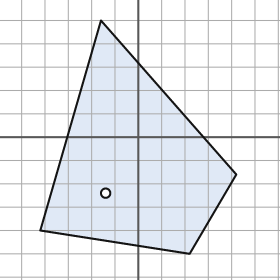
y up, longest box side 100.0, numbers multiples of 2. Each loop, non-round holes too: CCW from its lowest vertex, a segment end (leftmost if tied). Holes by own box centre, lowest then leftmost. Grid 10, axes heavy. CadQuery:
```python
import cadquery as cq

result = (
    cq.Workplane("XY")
    .moveTo(22.0, -50.0)
    .lineTo(42.0, -16.0)
    .lineTo(-16.0, 50.0)
    .lineTo(-42.0, -40.0)
    .close()
    .moveTo(-14.0, -24.0)
    .circle(2.0)
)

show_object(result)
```